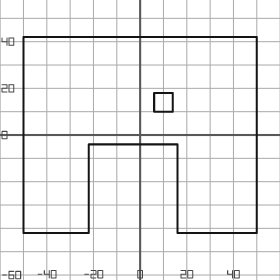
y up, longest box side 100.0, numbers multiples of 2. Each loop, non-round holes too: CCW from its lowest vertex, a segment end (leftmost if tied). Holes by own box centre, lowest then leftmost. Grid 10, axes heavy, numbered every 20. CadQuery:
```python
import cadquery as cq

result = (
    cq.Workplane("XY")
    .moveTo(-50.0, -42.0)
    .lineTo(-22.0, -42.0)
    .lineTo(-22.0, -4.0)
    .lineTo(16.0, -4.0)
    .lineTo(16.0, -42.0)
    .lineTo(50.0, -42.0)
    .lineTo(50.0, 42.0)
    .lineTo(-50.0, 42.0)
    .close()
    .moveTo(6.0, 10.0)
    .lineTo(14.0, 10.0)
    .lineTo(14.0, 18.0)
    .lineTo(6.0, 18.0)
    .close()
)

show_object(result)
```